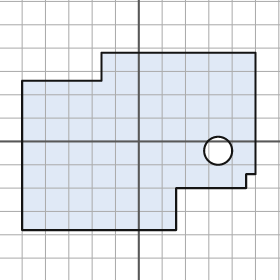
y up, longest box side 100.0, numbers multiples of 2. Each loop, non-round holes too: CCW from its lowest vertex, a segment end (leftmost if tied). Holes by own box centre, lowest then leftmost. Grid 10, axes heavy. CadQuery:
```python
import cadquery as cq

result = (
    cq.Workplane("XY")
    .moveTo(-50.0, -38.0)
    .lineTo(16.0, -38.0)
    .lineTo(16.0, -20.0)
    .lineTo(46.0, -20.0)
    .lineTo(46.0, -14.0)
    .lineTo(50.0, -14.0)
    .lineTo(50.0, 38.0)
    .lineTo(-16.0, 38.0)
    .lineTo(-16.0, 26.0)
    .lineTo(-50.0, 26.0)
    .close()
    .moveTo(34.0, -4.0)
    .circle(6.0)
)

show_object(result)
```